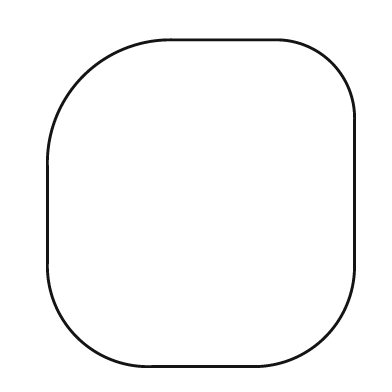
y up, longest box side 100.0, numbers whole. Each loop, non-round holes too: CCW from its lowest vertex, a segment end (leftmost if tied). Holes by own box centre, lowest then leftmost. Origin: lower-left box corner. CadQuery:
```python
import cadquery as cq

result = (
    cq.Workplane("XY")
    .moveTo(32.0, 0.0)
    .lineTo(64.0, 0.0)
    .threePointArc((85.0, 9.0), (94.0, 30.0))
    .lineTo(94.0, 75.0)
    .threePointArc((87.0, 93.0), (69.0, 100.0))
    .lineTo(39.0, 100.0)
    .threePointArc((11.0, 89.0), (0.0, 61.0))
    .lineTo(0.0, 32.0)
    .threePointArc((9.0, 9.0), (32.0, 0.0))
    .close()
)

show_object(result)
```